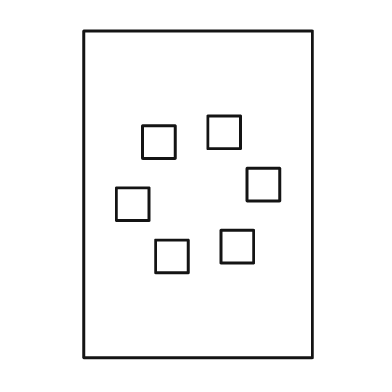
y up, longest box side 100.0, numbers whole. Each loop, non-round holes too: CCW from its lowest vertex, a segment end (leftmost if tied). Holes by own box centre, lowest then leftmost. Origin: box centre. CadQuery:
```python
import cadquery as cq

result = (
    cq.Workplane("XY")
    .moveTo(-35.0, -50.0)
    .lineTo(35.0, -50.0)
    .lineTo(35.0, 50.0)
    .lineTo(-35.0, 50.0)
    .close()
    .moveTo(-13.0, -24.0)
    .lineTo(-3.0, -24.0)
    .lineTo(-3.0, -14.0)
    .lineTo(-13.0, -14.0)
    .close()
    .moveTo(7.0, -21.0)
    .lineTo(17.0, -21.0)
    .lineTo(17.0, -11.0)
    .lineTo(7.0, -11.0)
    .close()
    .moveTo(-25.0, -8.0)
    .lineTo(-15.0, -8.0)
    .lineTo(-15.0, 2.0)
    .lineTo(-25.0, 2.0)
    .close()
    .moveTo(15.0, -2.0)
    .lineTo(25.0, -2.0)
    .lineTo(25.0, 8.0)
    .lineTo(15.0, 8.0)
    .close()
    .moveTo(-17.0, 11.0)
    .lineTo(-7.0, 11.0)
    .lineTo(-7.0, 21.0)
    .lineTo(-17.0, 21.0)
    .close()
    .moveTo(3.0, 14.0)
    .lineTo(13.0, 14.0)
    .lineTo(13.0, 24.0)
    .lineTo(3.0, 24.0)
    .close()
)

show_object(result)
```